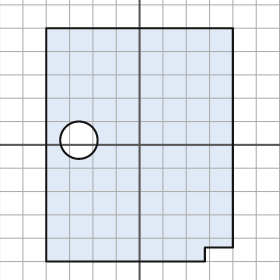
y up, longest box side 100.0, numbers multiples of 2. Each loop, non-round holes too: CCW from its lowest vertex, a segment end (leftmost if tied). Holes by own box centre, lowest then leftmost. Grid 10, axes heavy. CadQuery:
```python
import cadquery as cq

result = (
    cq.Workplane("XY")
    .moveTo(-40.0, -50.0)
    .lineTo(28.0, -50.0)
    .lineTo(28.0, -44.0)
    .lineTo(40.0, -44.0)
    .lineTo(40.0, 50.0)
    .lineTo(-40.0, 50.0)
    .close()
    .moveTo(-26.0, 2.0)
    .circle(8.0)
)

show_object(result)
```